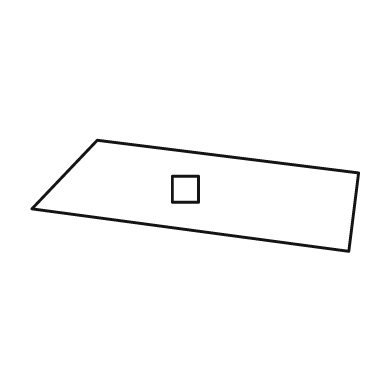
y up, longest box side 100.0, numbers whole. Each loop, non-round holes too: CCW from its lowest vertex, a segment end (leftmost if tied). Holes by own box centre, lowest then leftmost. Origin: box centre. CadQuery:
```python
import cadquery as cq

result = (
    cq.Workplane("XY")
    .moveTo(47.0, -17.0)
    .lineTo(50.0, 7.0)
    .lineTo(-30.0, 17.0)
    .lineTo(-50.0, -4.0)
    .close()
    .moveTo(-7.0, -2.0)
    .lineTo(1.0, -2.0)
    .lineTo(1.0, 6.0)
    .lineTo(-7.0, 6.0)
    .close()
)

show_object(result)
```